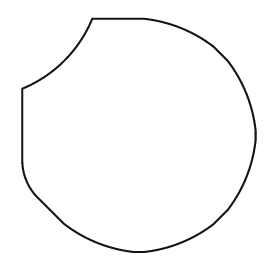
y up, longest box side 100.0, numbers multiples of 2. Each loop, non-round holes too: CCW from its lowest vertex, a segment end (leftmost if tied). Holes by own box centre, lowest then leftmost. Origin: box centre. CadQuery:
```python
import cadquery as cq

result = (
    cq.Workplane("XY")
    .moveTo(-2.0, -50.0)
    .lineTo(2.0, -50.0)
    .threePointArc((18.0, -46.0), (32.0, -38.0))
    .lineTo(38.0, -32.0)
    .threePointArc((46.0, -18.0), (50.0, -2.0))
    .lineTo(50.0, 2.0)
    .threePointArc((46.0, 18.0), (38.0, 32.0))
    .lineTo(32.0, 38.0)
    .threePointArc((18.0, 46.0), (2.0, 50.0))
    .lineTo(-20.0, 50.0)
    .threePointArc((-32.0, 32.0), (-50.0, 20.0))
    .lineTo(-50.0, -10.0)
    .threePointArc((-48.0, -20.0), (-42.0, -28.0))
    .lineTo(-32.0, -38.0)
    .threePointArc((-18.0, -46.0), (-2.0, -50.0))
    .close()
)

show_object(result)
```